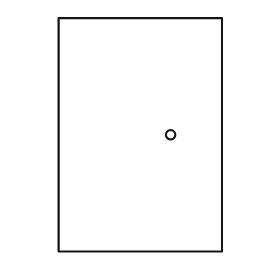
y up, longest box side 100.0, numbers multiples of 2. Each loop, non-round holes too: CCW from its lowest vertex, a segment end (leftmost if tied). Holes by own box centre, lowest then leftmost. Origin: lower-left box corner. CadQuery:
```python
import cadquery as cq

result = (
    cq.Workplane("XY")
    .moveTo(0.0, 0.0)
    .lineTo(70.0, 0.0)
    .lineTo(70.0, 100.0)
    .lineTo(0.0, 100.0)
    .close()
    .moveTo(48.0, 50.0)
    .circle(2.0)
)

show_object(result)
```